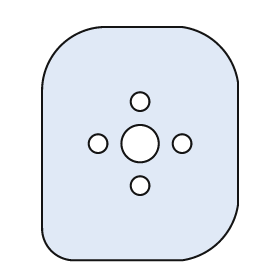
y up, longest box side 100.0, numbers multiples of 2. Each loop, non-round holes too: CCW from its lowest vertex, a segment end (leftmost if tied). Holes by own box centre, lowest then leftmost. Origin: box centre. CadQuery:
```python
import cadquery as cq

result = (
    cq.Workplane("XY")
    .moveTo(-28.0, -50.0)
    .lineTo(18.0, -50.0)
    .threePointArc((34.0, -42.0), (42.0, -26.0))
    .lineTo(42.0, 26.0)
    .threePointArc((34.0, 42.0), (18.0, 50.0))
    .lineTo(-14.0, 50.0)
    .threePointArc((-34.0, 42.0), (-42.0, 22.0))
    .lineTo(-42.0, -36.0)
    .threePointArc((-38.0, -46.0), (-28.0, -50.0))
    .close()
    .moveTo(0.0, -18.0)
    .circle(4.0)
    .moveTo(-18.0, 0.0)
    .circle(4.0)
    .moveTo(0.0, 0.0)
    .circle(8.0)
    .moveTo(18.0, 0.0)
    .circle(4.0)
    .moveTo(0.0, 18.0)
    .circle(4.0)
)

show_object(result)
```